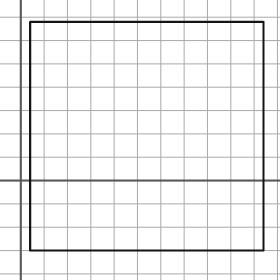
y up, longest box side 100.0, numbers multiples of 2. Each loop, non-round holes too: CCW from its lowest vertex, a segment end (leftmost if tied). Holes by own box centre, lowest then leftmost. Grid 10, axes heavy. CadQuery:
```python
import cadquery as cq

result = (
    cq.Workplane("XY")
    .moveTo(4.0, -30.0)
    .lineTo(104.0, -30.0)
    .lineTo(104.0, 68.0)
    .lineTo(4.0, 68.0)
    .close()
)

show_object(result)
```